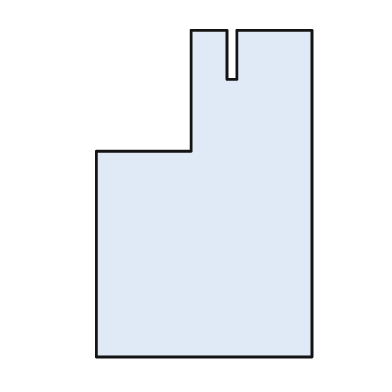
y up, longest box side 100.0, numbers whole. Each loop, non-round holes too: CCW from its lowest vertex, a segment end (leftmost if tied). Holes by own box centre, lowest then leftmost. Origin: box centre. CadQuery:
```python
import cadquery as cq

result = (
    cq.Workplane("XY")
    .moveTo(-33.0, -50.0)
    .lineTo(33.0, -50.0)
    .lineTo(33.0, 50.0)
    .lineTo(10.0, 50.0)
    .lineTo(10.0, 35.0)
    .lineTo(7.0, 35.0)
    .lineTo(7.0, 50.0)
    .lineTo(-4.0, 50.0)
    .lineTo(-4.0, 13.0)
    .lineTo(-33.0, 13.0)
    .close()
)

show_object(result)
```